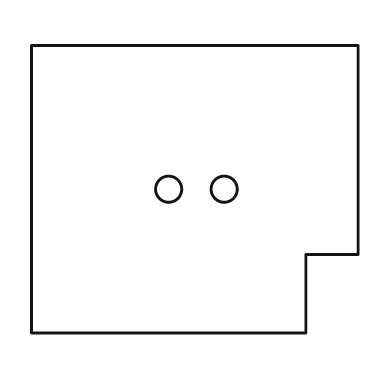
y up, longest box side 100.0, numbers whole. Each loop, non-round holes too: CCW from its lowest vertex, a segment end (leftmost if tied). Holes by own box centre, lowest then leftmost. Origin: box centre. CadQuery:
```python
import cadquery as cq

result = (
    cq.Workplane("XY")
    .moveTo(-50.0, -44.0)
    .lineTo(34.0, -44.0)
    .lineTo(34.0, -20.0)
    .lineTo(50.0, -20.0)
    .lineTo(50.0, 44.0)
    .lineTo(-50.0, 44.0)
    .close()
    .moveTo(-8.0, 0.0)
    .circle(4.0)
    .moveTo(9.0, 0.0)
    .circle(4.0)
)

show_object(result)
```